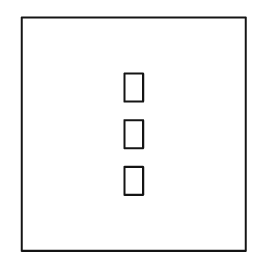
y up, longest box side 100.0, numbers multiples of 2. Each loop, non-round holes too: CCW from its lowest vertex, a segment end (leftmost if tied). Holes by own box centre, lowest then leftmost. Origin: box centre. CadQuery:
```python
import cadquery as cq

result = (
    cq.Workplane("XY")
    .moveTo(-48.0, -50.0)
    .lineTo(48.0, -50.0)
    .lineTo(48.0, 50.0)
    .lineTo(-48.0, 50.0)
    .close()
    .moveTo(-4.0, -26.0)
    .lineTo(4.0, -26.0)
    .lineTo(4.0, -14.0)
    .lineTo(-4.0, -14.0)
    .close()
    .moveTo(-4.0, -6.0)
    .lineTo(4.0, -6.0)
    .lineTo(4.0, 6.0)
    .lineTo(-4.0, 6.0)
    .close()
    .moveTo(-4.0, 14.0)
    .lineTo(4.0, 14.0)
    .lineTo(4.0, 26.0)
    .lineTo(-4.0, 26.0)
    .close()
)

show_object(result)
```